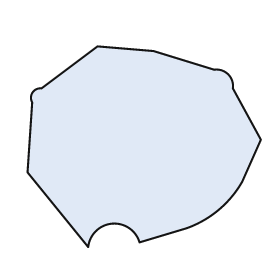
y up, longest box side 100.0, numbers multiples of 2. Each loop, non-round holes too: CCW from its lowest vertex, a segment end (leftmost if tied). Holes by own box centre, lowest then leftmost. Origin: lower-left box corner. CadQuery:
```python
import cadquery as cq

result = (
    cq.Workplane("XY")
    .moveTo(26.0, 0.0)
    .threePointArc((36.0, 10.0), (48.0, 2.0))
    .lineTo(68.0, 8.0)
    .threePointArc((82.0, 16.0), (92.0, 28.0))
    .lineTo(100.0, 46.0)
    .lineTo(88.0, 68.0)
    .threePointArc((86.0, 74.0), (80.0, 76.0))
    .lineTo(54.0, 84.0)
    .lineTo(30.0, 86.0)
    .lineTo(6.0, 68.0)
    .threePointArc((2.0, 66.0), (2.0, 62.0))
    .lineTo(0.0, 32.0)
    .close()
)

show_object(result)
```